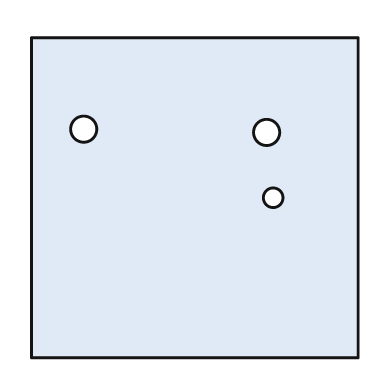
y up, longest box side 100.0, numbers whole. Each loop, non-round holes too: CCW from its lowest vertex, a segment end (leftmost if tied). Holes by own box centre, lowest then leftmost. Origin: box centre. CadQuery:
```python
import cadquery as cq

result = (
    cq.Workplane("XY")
    .moveTo(-50.0, -49.0)
    .lineTo(50.0, -49.0)
    .lineTo(50.0, 49.0)
    .lineTo(-50.0, 49.0)
    .close()
    .moveTo(24.0, 0.0)
    .circle(3.0)
    .moveTo(22.0, 20.0)
    .circle(4.0)
    .moveTo(-34.0, 21.0)
    .circle(4.0)
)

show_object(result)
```